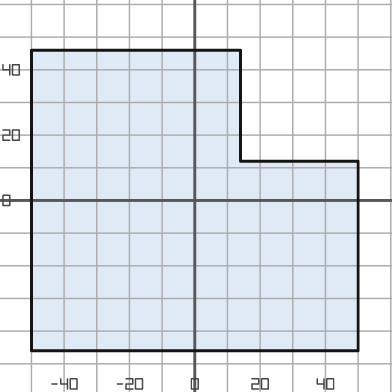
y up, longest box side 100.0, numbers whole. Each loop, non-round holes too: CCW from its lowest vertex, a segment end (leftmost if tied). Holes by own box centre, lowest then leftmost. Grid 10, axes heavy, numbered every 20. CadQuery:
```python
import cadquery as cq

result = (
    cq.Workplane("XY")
    .moveTo(-50.0, -46.0)
    .lineTo(50.0, -46.0)
    .lineTo(50.0, 12.0)
    .lineTo(14.0, 12.0)
    .lineTo(14.0, 46.0)
    .lineTo(-50.0, 46.0)
    .close()
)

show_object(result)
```